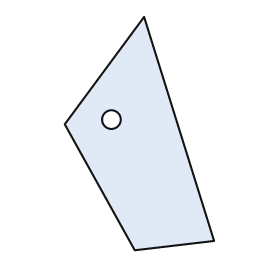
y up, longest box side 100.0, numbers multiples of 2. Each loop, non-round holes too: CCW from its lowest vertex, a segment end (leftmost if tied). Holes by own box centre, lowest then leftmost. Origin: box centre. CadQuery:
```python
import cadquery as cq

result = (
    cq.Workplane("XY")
    .moveTo(-2.0, -50.0)
    .lineTo(32.0, -46.0)
    .lineTo(2.0, 50.0)
    .lineTo(-32.0, 4.0)
    .close()
    .moveTo(-12.0, 6.0)
    .circle(4.0)
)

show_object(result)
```